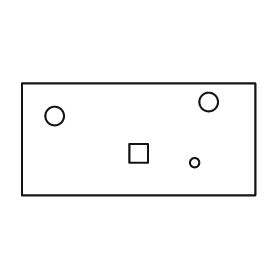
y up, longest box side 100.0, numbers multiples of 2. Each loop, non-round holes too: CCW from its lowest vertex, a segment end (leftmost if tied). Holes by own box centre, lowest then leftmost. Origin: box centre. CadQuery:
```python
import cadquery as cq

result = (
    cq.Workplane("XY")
    .moveTo(-50.0, -24.0)
    .lineTo(50.0, -24.0)
    .lineTo(50.0, 24.0)
    .lineTo(-50.0, 24.0)
    .close()
    .moveTo(24.0, -10.0)
    .circle(2.0)
    .moveTo(-4.0, -10.0)
    .lineTo(4.0, -10.0)
    .lineTo(4.0, -2.0)
    .lineTo(-4.0, -2.0)
    .close()
    .moveTo(-36.0, 10.0)
    .circle(4.0)
    .moveTo(30.0, 16.0)
    .circle(4.0)
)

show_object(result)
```